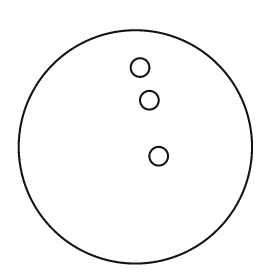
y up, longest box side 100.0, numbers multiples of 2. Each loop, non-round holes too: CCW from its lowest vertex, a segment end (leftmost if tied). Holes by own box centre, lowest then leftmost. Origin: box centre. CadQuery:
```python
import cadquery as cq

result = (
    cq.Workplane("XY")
    .moveTo(0.0, 0.0)
    .circle(50.0)
    .moveTo(10.0, -4.0)
    .circle(4.0)
    .moveTo(6.0, 20.0)
    .circle(4.0)
    .moveTo(2.0, 34.0)
    .circle(4.0)
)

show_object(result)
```